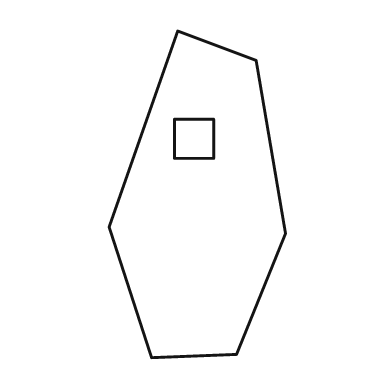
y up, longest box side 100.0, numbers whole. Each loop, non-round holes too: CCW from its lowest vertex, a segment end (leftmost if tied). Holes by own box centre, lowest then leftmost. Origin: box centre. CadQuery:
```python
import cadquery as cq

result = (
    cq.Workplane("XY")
    .moveTo(-14.0, -50.0)
    .lineTo(12.0, -49.0)
    .lineTo(27.0, -12.0)
    .lineTo(18.0, 41.0)
    .lineTo(-6.0, 50.0)
    .lineTo(-27.0, -10.0)
    .close()
    .moveTo(-7.0, 11.0)
    .lineTo(5.0, 11.0)
    .lineTo(5.0, 23.0)
    .lineTo(-7.0, 23.0)
    .close()
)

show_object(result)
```